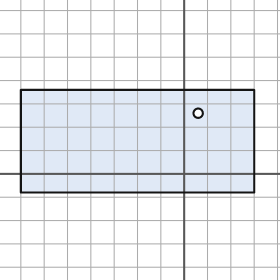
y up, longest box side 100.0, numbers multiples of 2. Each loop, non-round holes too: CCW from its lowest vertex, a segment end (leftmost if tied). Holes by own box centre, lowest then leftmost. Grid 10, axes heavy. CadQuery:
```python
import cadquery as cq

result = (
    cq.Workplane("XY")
    .moveTo(-70.0, -8.0)
    .lineTo(30.0, -8.0)
    .lineTo(30.0, 36.0)
    .lineTo(-70.0, 36.0)
    .close()
    .moveTo(6.0, 26.0)
    .circle(2.0)
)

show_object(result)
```